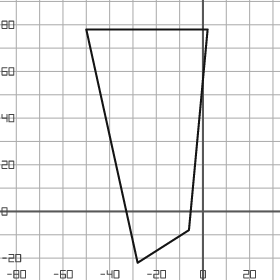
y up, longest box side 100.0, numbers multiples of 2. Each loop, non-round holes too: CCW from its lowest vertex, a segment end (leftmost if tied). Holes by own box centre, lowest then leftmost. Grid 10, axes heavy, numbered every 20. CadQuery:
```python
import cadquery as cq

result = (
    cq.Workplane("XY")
    .moveTo(-28.0, -22.0)
    .lineTo(-6.0, -8.0)
    .lineTo(2.0, 78.0)
    .lineTo(-50.0, 78.0)
    .close()
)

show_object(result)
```